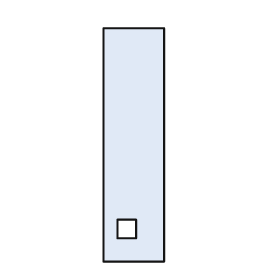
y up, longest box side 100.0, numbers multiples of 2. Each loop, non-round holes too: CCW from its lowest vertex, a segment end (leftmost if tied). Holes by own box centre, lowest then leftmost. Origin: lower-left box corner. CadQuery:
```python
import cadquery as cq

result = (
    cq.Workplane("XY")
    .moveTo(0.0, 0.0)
    .lineTo(26.0, 0.0)
    .lineTo(26.0, 100.0)
    .lineTo(0.0, 100.0)
    .close()
    .moveTo(6.0, 10.0)
    .lineTo(14.0, 10.0)
    .lineTo(14.0, 18.0)
    .lineTo(6.0, 18.0)
    .close()
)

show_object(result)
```